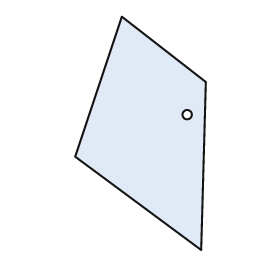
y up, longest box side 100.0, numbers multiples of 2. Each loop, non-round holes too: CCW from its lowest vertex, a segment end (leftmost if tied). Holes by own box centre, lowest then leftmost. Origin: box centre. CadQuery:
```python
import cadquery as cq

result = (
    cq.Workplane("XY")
    .moveTo(26.0, -50.0)
    .lineTo(28.0, 22.0)
    .lineTo(-8.0, 50.0)
    .lineTo(-28.0, -10.0)
    .close()
    .moveTo(20.0, 8.0)
    .circle(2.0)
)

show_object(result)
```